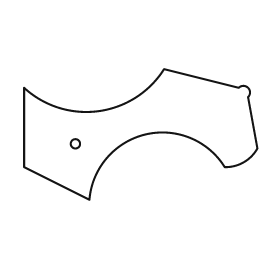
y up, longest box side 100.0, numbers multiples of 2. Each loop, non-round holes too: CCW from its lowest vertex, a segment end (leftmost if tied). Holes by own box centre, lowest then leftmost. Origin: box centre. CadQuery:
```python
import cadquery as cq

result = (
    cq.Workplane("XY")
    .moveTo(-22.0, -28.0)
    .threePointArc((2.0, 0.0), (36.0, -14.0))
    .threePointArc((44.0, -12.0), (50.0, -6.0))
    .lineTo(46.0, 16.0)
    .threePointArc((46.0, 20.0), (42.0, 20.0))
    .lineTo(10.0, 28.0)
    .threePointArc((-18.0, 10.0), (-50.0, 20.0))
    .lineTo(-50.0, -14.0)
    .close()
    .moveTo(-28.0, -4.0)
    .circle(2.0)
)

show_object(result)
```